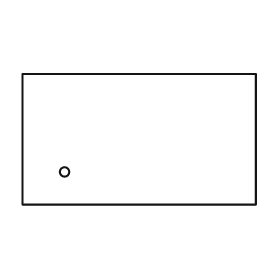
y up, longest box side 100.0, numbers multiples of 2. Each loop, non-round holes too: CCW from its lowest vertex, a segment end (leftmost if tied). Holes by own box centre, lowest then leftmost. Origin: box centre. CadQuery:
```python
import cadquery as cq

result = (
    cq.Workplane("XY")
    .moveTo(-50.0, -28.0)
    .lineTo(50.0, -28.0)
    .lineTo(50.0, 28.0)
    .lineTo(-50.0, 28.0)
    .close()
    .moveTo(-32.0, -14.0)
    .circle(2.0)
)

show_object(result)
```